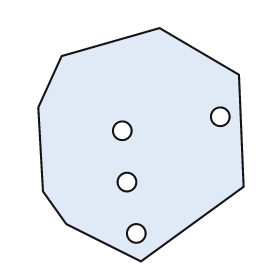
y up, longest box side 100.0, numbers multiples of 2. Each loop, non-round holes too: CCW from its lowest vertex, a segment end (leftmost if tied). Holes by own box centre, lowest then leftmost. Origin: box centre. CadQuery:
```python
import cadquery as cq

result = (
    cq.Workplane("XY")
    .moveTo(0.0, -50.0)
    .lineTo(44.0, -18.0)
    .lineTo(42.0, 30.0)
    .lineTo(8.0, 50.0)
    .lineTo(-34.0, 38.0)
    .lineTo(-44.0, 16.0)
    .lineTo(-42.0, -20.0)
    .lineTo(-32.0, -34.0)
    .close()
    .moveTo(-2.0, -38.0)
    .circle(4.0)
    .moveTo(-6.0, -16.0)
    .circle(4.0)
    .moveTo(-8.0, 6.0)
    .circle(4.0)
    .moveTo(34.0, 12.0)
    .circle(4.0)
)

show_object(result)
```